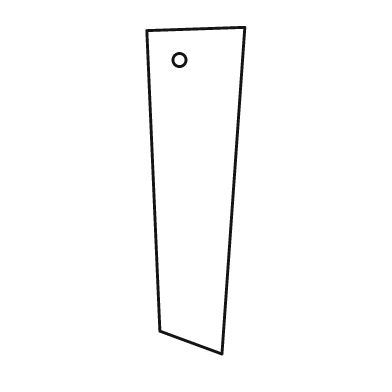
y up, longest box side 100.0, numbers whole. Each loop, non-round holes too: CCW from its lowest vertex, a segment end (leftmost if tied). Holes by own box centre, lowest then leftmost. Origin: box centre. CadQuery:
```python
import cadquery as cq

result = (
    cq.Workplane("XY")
    .moveTo(8.0, -50.0)
    .lineTo(15.0, 50.0)
    .lineTo(-15.0, 49.0)
    .lineTo(-11.0, -43.0)
    .close()
    .moveTo(-5.0, 40.0)
    .circle(2.0)
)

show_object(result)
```